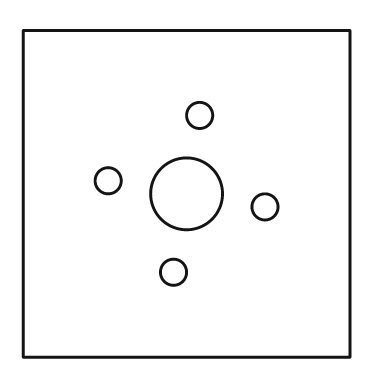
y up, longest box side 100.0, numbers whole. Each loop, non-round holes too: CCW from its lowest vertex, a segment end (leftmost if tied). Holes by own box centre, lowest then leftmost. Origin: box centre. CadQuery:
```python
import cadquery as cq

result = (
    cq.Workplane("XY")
    .moveTo(-50.0, -50.0)
    .lineTo(50.0, -50.0)
    .lineTo(50.0, 50.0)
    .lineTo(-50.0, 50.0)
    .close()
    .moveTo(-4.0, -24.0)
    .circle(4.0)
    .moveTo(24.0, -4.0)
    .circle(4.0)
    .moveTo(0.0, 0.0)
    .circle(11.0)
    .moveTo(-24.0, 4.0)
    .circle(4.0)
    .moveTo(4.0, 24.0)
    .circle(4.0)
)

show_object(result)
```